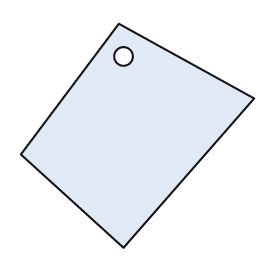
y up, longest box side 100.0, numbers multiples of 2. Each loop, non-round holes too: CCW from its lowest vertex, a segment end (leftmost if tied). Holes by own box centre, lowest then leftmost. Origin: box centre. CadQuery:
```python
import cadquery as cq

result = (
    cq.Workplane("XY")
    .moveTo(-6.0, -48.0)
    .lineTo(50.0, 16.0)
    .lineTo(-8.0, 48.0)
    .lineTo(-50.0, -8.0)
    .close()
    .moveTo(-6.0, 34.0)
    .circle(4.0)
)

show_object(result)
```